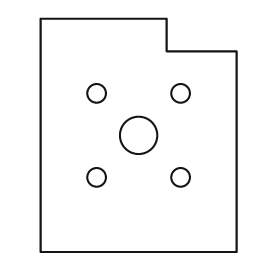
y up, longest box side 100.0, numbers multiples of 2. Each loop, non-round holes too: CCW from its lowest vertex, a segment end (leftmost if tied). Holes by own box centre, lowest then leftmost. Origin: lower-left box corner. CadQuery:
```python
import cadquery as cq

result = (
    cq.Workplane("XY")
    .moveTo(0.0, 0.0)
    .lineTo(84.0, 0.0)
    .lineTo(84.0, 86.0)
    .lineTo(54.0, 86.0)
    .lineTo(54.0, 100.0)
    .lineTo(0.0, 100.0)
    .close()
    .moveTo(24.0, 32.0)
    .circle(4.0)
    .moveTo(60.0, 32.0)
    .circle(4.0)
    .moveTo(42.0, 50.0)
    .circle(8.0)
    .moveTo(24.0, 68.0)
    .circle(4.0)
    .moveTo(60.0, 68.0)
    .circle(4.0)
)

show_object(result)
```